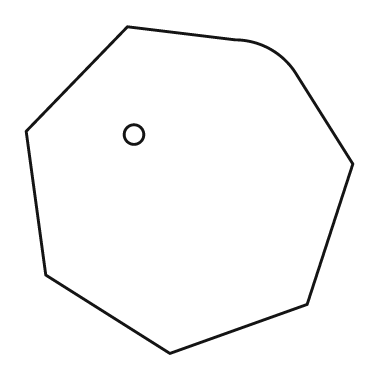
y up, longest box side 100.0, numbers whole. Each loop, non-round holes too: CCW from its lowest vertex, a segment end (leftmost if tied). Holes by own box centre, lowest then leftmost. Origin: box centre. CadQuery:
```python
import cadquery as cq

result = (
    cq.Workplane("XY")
    .moveTo(-6.0, -50.0)
    .lineTo(36.0, -35.0)
    .lineTo(50.0, 8.0)
    .lineTo(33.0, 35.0)
    .threePointArc((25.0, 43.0), (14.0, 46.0))
    .lineTo(-19.0, 50.0)
    .lineTo(-50.0, 18.0)
    .lineTo(-44.0, -26.0)
    .close()
    .moveTo(-17.0, 17.0)
    .circle(3.0)
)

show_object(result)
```